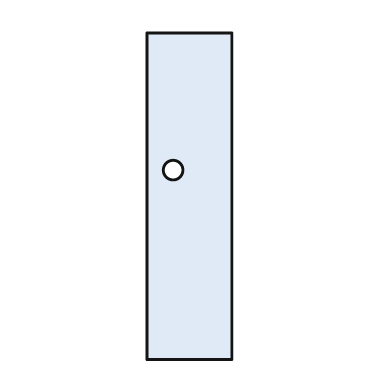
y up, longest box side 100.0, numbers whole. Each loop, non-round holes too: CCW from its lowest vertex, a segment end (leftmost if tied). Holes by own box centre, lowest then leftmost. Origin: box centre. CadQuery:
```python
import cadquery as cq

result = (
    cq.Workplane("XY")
    .moveTo(-13.0, -50.0)
    .lineTo(13.0, -50.0)
    .lineTo(13.0, 50.0)
    .lineTo(-13.0, 50.0)
    .close()
    .moveTo(-5.0, 8.0)
    .circle(3.0)
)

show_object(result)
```